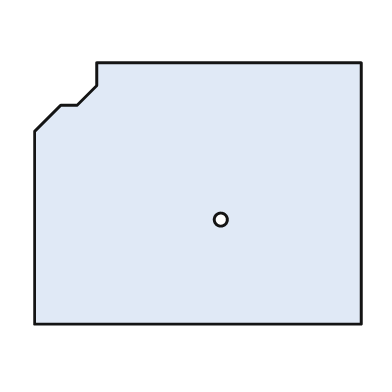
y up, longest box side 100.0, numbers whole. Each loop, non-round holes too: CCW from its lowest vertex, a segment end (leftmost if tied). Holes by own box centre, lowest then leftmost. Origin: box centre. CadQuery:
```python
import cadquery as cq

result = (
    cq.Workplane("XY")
    .moveTo(-50.0, -40.0)
    .lineTo(50.0, -40.0)
    .lineTo(50.0, 40.0)
    .lineTo(-31.0, 40.0)
    .lineTo(-31.0, 33.0)
    .lineTo(-37.0, 27.0)
    .lineTo(-42.0, 27.0)
    .lineTo(-50.0, 19.0)
    .close()
    .moveTo(7.0, -8.0)
    .circle(2.0)
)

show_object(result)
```